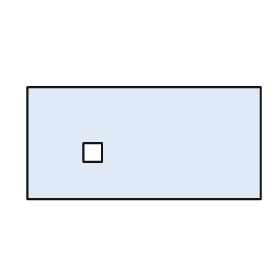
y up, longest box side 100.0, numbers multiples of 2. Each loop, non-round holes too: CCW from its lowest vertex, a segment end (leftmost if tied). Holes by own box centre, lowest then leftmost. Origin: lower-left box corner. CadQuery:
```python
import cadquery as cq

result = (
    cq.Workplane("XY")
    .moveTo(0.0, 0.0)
    .lineTo(100.0, 0.0)
    .lineTo(100.0, 48.0)
    .lineTo(0.0, 48.0)
    .close()
    .moveTo(24.0, 16.0)
    .lineTo(32.0, 16.0)
    .lineTo(32.0, 24.0)
    .lineTo(24.0, 24.0)
    .close()
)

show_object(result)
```